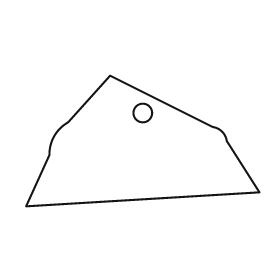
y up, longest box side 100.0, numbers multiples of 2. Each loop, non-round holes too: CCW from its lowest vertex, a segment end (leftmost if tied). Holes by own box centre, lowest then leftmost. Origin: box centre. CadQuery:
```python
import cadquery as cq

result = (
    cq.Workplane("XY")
    .moveTo(-50.0, -28.0)
    .lineTo(50.0, -22.0)
    .lineTo(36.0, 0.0)
    .threePointArc((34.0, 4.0), (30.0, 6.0))
    .lineTo(-14.0, 28.0)
    .lineTo(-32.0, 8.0)
    .threePointArc((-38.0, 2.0), (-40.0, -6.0))
    .close()
    .moveTo(0.0, 12.0)
    .circle(4.0)
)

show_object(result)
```